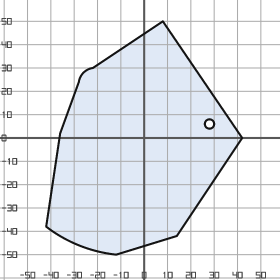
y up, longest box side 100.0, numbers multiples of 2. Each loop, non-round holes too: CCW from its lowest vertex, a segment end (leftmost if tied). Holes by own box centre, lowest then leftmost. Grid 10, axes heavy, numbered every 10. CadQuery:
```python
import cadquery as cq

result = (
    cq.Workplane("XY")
    .moveTo(-12.0, -50.0)
    .lineTo(14.0, -42.0)
    .lineTo(42.0, 0.0)
    .lineTo(8.0, 50.0)
    .lineTo(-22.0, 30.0)
    .threePointArc((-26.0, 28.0), (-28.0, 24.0))
    .lineTo(-36.0, 2.0)
    .lineTo(-42.0, -38.0)
    .threePointArc((-28.0, -46.0), (-12.0, -50.0))
    .close()
    .moveTo(28.0, 6.0)
    .circle(2.0)
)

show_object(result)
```